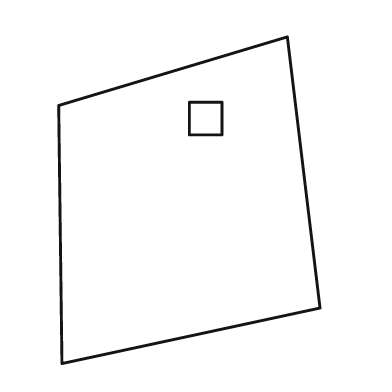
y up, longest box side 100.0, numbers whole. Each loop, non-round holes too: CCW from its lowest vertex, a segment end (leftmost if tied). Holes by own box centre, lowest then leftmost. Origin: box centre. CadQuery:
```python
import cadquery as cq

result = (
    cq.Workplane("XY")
    .moveTo(-39.0, -50.0)
    .lineTo(40.0, -33.0)
    .lineTo(30.0, 50.0)
    .lineTo(-40.0, 29.0)
    .close()
    .moveTo(0.0, 20.0)
    .lineTo(10.0, 20.0)
    .lineTo(10.0, 30.0)
    .lineTo(0.0, 30.0)
    .close()
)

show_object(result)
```